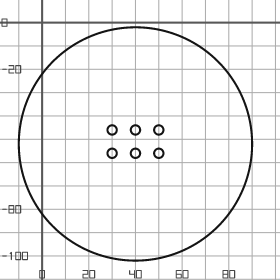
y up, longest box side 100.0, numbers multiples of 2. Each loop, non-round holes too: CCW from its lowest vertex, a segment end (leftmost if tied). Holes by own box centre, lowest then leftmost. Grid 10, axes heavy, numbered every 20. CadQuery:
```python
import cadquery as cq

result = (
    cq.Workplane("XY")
    .moveTo(40.0, -52.0)
    .circle(50.0)
    .moveTo(30.0, -56.0)
    .circle(2.0)
    .moveTo(40.0, -56.0)
    .circle(2.0)
    .moveTo(50.0, -56.0)
    .circle(2.0)
    .moveTo(30.0, -46.0)
    .circle(2.0)
    .moveTo(40.0, -46.0)
    .circle(2.0)
    .moveTo(50.0, -46.0)
    .circle(2.0)
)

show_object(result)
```